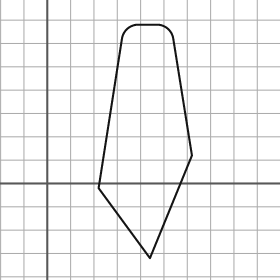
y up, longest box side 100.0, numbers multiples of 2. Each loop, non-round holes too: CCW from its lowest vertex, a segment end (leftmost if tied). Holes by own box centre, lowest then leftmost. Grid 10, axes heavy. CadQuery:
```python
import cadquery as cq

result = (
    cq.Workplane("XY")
    .moveTo(44.0, -32.0)
    .lineTo(62.0, 12.0)
    .lineTo(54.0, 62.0)
    .threePointArc((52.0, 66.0), (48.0, 68.0))
    .lineTo(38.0, 68.0)
    .threePointArc((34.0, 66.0), (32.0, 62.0))
    .lineTo(22.0, -2.0)
    .close()
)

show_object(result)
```